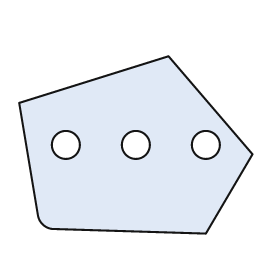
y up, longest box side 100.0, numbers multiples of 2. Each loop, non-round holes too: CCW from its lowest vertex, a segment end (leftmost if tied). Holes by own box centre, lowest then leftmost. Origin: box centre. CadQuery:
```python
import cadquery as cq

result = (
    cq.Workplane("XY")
    .moveTo(30.0, -38.0)
    .lineTo(50.0, -4.0)
    .lineTo(14.0, 38.0)
    .lineTo(-50.0, 18.0)
    .lineTo(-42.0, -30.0)
    .threePointArc((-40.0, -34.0), (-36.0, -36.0))
    .close()
    .moveTo(-30.0, 0.0)
    .circle(6.0)
    .moveTo(0.0, 0.0)
    .circle(6.0)
    .moveTo(30.0, 0.0)
    .circle(6.0)
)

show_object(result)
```